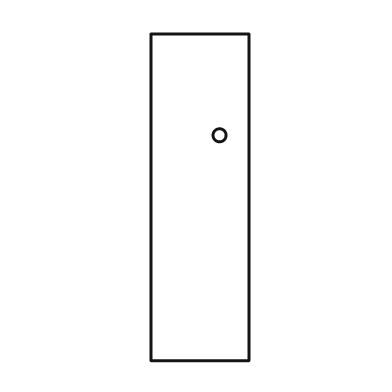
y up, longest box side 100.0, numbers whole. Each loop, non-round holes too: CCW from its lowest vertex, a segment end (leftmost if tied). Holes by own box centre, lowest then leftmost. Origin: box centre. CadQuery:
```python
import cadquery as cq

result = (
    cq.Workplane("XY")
    .moveTo(-15.0, -50.0)
    .lineTo(15.0, -50.0)
    .lineTo(15.0, 50.0)
    .lineTo(-15.0, 50.0)
    .close()
    .moveTo(6.0, 19.0)
    .circle(2.0)
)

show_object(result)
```